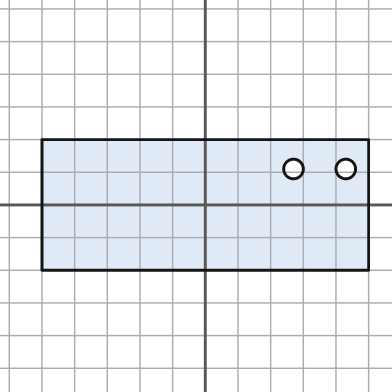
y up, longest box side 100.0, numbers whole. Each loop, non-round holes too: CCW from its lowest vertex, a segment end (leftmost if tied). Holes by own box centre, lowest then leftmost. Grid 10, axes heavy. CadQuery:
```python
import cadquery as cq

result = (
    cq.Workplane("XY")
    .moveTo(-50.0, -20.0)
    .lineTo(50.0, -20.0)
    .lineTo(50.0, 20.0)
    .lineTo(-50.0, 20.0)
    .close()
    .moveTo(27.0, 11.0)
    .circle(3.0)
    .moveTo(43.0, 11.0)
    .circle(3.0)
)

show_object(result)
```